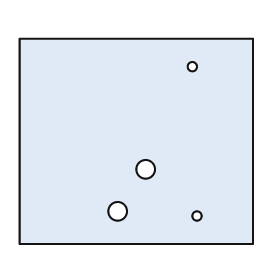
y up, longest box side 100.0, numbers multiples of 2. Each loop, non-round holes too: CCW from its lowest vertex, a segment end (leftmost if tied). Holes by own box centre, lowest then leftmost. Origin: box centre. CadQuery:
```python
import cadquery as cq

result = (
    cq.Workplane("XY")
    .moveTo(-50.0, -44.0)
    .lineTo(50.0, -44.0)
    .lineTo(50.0, 44.0)
    .lineTo(-50.0, 44.0)
    .close()
    .moveTo(26.0, -32.0)
    .circle(2.0)
    .moveTo(-8.0, -30.0)
    .circle(4.0)
    .moveTo(4.0, -12.0)
    .circle(4.0)
    .moveTo(24.0, 32.0)
    .circle(2.0)
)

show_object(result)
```